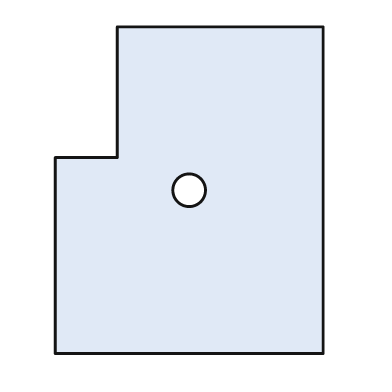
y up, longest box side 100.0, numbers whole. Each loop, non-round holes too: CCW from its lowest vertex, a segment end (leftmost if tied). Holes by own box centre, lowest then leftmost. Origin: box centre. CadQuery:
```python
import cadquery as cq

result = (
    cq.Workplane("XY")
    .moveTo(-41.0, -50.0)
    .lineTo(41.0, -50.0)
    .lineTo(41.0, 50.0)
    .lineTo(-22.0, 50.0)
    .lineTo(-22.0, 10.0)
    .lineTo(-41.0, 10.0)
    .close()
    .moveTo(0.0, 0.0)
    .circle(5.0)
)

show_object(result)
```